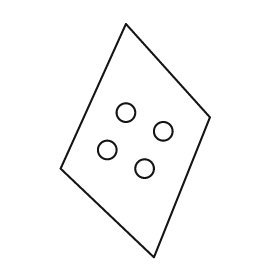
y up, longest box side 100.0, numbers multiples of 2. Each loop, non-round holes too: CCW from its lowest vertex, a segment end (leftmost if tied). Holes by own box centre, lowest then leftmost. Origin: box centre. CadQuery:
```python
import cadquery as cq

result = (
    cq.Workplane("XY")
    .moveTo(8.0, -50.0)
    .lineTo(32.0, 10.0)
    .lineTo(-4.0, 50.0)
    .lineTo(-32.0, -12.0)
    .close()
    .moveTo(4.0, -12.0)
    .circle(4.0)
    .moveTo(-12.0, -4.0)
    .circle(4.0)
    .moveTo(12.0, 4.0)
    .circle(4.0)
    .moveTo(-4.0, 12.0)
    .circle(4.0)
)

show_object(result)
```